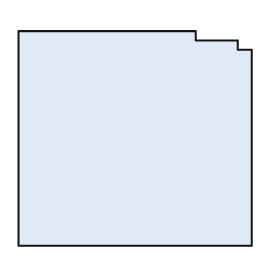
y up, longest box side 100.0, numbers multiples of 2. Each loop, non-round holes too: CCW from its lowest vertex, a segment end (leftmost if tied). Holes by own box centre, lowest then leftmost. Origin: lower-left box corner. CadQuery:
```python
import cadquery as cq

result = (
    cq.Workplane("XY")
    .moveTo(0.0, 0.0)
    .lineTo(100.0, 0.0)
    .lineTo(100.0, 84.0)
    .lineTo(94.0, 84.0)
    .lineTo(94.0, 88.0)
    .lineTo(76.0, 88.0)
    .lineTo(76.0, 92.0)
    .lineTo(0.0, 92.0)
    .close()
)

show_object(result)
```